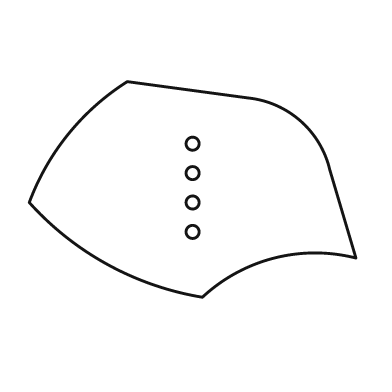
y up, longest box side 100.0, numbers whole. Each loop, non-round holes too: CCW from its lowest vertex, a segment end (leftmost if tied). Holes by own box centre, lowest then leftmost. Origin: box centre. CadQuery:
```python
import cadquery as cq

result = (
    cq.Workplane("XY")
    .moveTo(3.0, -33.0)
    .threePointArc((25.0, -21.0), (50.0, -21.0))
    .lineTo(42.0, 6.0)
    .threePointArc((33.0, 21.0), (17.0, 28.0))
    .lineTo(-20.0, 33.0)
    .threePointArc((-38.0, 17.0), (-50.0, -4.0))
    .threePointArc((-26.0, -23.0), (3.0, -33.0))
    .close()
    .moveTo(0.0, -13.0)
    .circle(2.0)
    .moveTo(0.0, -4.0)
    .circle(2.0)
    .moveTo(0.0, 5.0)
    .circle(2.0)
    .moveTo(0.0, 14.0)
    .circle(2.0)
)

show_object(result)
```